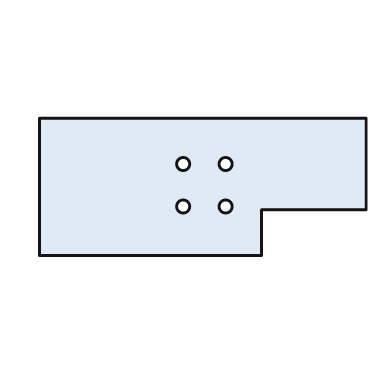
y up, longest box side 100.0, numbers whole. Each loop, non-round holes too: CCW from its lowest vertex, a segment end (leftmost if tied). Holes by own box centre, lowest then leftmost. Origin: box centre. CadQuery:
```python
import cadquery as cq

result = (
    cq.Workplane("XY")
    .moveTo(-50.0, -21.0)
    .lineTo(18.0, -21.0)
    .lineTo(18.0, -7.0)
    .lineTo(50.0, -7.0)
    .lineTo(50.0, 21.0)
    .lineTo(-50.0, 21.0)
    .close()
    .moveTo(-6.0, -6.0)
    .circle(2.0)
    .moveTo(7.0, -6.0)
    .circle(2.0)
    .moveTo(-6.0, 7.0)
    .circle(2.0)
    .moveTo(7.0, 7.0)
    .circle(2.0)
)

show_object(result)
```